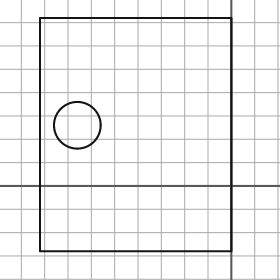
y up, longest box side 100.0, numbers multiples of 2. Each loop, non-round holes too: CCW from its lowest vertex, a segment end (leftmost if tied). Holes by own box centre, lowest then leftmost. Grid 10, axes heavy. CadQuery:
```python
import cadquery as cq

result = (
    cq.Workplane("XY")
    .moveTo(-82.0, -28.0)
    .lineTo(0.0, -28.0)
    .lineTo(0.0, 72.0)
    .lineTo(-82.0, 72.0)
    .close()
    .moveTo(-66.0, 26.0)
    .circle(10.0)
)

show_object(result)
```